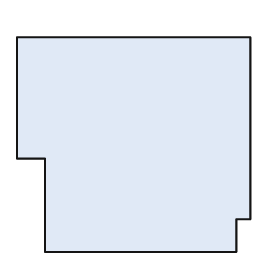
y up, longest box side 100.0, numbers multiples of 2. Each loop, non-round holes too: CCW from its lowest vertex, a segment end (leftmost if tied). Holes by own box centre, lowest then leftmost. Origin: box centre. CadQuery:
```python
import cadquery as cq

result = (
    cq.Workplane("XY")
    .moveTo(-38.0, -46.0)
    .lineTo(44.0, -46.0)
    .lineTo(44.0, -32.0)
    .lineTo(50.0, -32.0)
    .lineTo(50.0, 46.0)
    .lineTo(-50.0, 46.0)
    .lineTo(-50.0, -6.0)
    .lineTo(-38.0, -6.0)
    .close()
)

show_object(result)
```